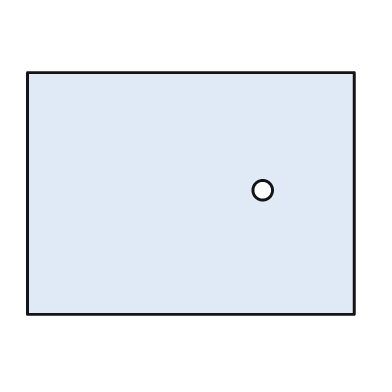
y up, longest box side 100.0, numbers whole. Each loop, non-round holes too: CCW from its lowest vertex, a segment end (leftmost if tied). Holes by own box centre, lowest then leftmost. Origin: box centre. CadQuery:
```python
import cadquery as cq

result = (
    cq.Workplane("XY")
    .moveTo(-50.0, -37.0)
    .lineTo(50.0, -37.0)
    .lineTo(50.0, 37.0)
    .lineTo(-50.0, 37.0)
    .close()
    .moveTo(22.0, 1.0)
    .circle(3.0)
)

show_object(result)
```